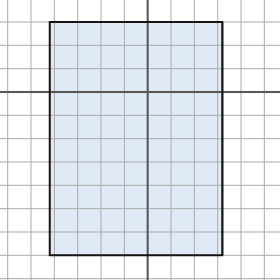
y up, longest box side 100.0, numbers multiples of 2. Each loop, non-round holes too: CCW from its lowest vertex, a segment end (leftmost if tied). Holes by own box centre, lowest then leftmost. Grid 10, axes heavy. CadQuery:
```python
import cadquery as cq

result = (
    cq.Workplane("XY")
    .moveTo(-42.0, -70.0)
    .lineTo(32.0, -70.0)
    .lineTo(32.0, 30.0)
    .lineTo(-42.0, 30.0)
    .close()
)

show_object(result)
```